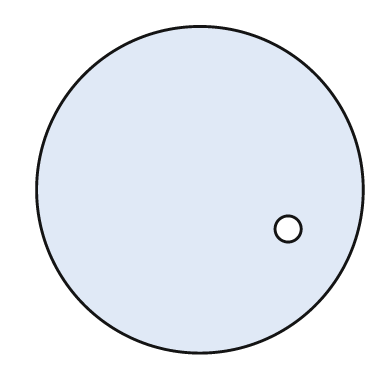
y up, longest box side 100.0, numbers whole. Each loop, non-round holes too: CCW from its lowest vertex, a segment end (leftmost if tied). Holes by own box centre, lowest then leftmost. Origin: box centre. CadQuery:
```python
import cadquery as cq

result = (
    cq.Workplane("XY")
    .moveTo(0.0, 0.0)
    .circle(50.0)
    .moveTo(27.0, -12.0)
    .circle(4.0)
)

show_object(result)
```